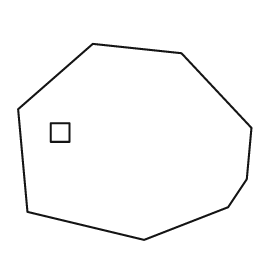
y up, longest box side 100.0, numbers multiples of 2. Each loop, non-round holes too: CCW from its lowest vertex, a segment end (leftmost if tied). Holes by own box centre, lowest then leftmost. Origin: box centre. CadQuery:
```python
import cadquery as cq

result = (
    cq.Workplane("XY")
    .moveTo(4.0, -42.0)
    .lineTo(40.0, -28.0)
    .lineTo(48.0, -16.0)
    .lineTo(50.0, 6.0)
    .lineTo(20.0, 38.0)
    .lineTo(-18.0, 42.0)
    .lineTo(-50.0, 14.0)
    .lineTo(-46.0, -30.0)
    .close()
    .moveTo(-36.0, 0.0)
    .lineTo(-28.0, 0.0)
    .lineTo(-28.0, 8.0)
    .lineTo(-36.0, 8.0)
    .close()
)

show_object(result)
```